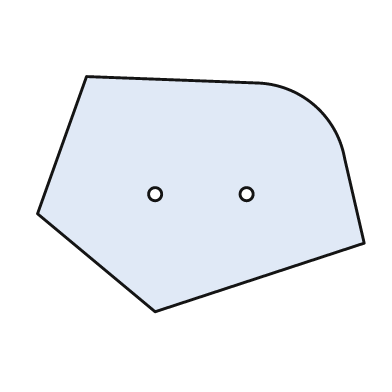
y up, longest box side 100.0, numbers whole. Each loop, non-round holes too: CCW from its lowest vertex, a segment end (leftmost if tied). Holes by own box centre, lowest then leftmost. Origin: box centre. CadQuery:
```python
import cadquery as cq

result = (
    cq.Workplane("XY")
    .moveTo(-14.0, -36.0)
    .lineTo(50.0, -15.0)
    .lineTo(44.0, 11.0)
    .threePointArc((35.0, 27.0), (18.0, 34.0))
    .lineTo(-35.0, 36.0)
    .lineTo(-50.0, -6.0)
    .close()
    .moveTo(-14.0, 0.0)
    .circle(2.0)
    .moveTo(14.0, 0.0)
    .circle(2.0)
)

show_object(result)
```